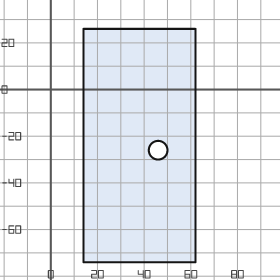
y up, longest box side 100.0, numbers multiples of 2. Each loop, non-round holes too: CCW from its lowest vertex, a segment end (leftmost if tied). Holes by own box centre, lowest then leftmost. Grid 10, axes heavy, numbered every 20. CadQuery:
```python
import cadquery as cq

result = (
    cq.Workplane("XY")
    .moveTo(14.0, -74.0)
    .lineTo(62.0, -74.0)
    .lineTo(62.0, 26.0)
    .lineTo(14.0, 26.0)
    .close()
    .moveTo(46.0, -26.0)
    .circle(4.0)
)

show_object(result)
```